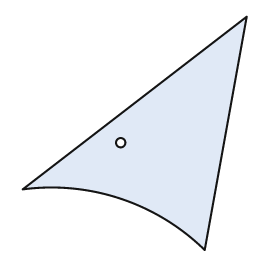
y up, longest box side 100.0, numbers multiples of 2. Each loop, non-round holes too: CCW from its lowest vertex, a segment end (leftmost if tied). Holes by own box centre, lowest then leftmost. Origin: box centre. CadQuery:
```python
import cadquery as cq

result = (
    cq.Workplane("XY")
    .moveTo(30.0, -50.0)
    .lineTo(48.0, 50.0)
    .lineTo(-48.0, -24.0)
    .threePointArc((-6.0, -28.0), (30.0, -50.0))
    .close()
    .moveTo(-6.0, -4.0)
    .circle(2.0)
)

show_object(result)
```